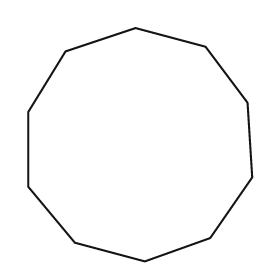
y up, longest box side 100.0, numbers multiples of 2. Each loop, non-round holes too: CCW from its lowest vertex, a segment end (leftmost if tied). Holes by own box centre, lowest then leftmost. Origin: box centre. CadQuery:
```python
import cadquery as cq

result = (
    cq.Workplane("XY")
    .moveTo(2.0, -50.0)
    .lineTo(30.0, -40.0)
    .lineTo(48.0, -14.0)
    .lineTo(46.0, 18.0)
    .lineTo(28.0, 42.0)
    .lineTo(-2.0, 50.0)
    .lineTo(-32.0, 40.0)
    .lineTo(-48.0, 14.0)
    .lineTo(-48.0, -18.0)
    .lineTo(-28.0, -42.0)
    .close()
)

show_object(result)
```